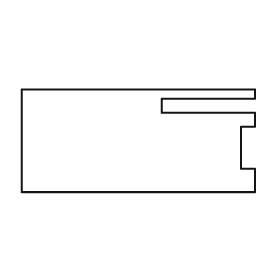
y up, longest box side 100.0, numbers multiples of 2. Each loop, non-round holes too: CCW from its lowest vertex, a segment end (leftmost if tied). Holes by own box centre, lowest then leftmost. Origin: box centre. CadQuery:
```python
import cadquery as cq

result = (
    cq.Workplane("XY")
    .moveTo(-50.0, -22.0)
    .lineTo(50.0, -22.0)
    .lineTo(50.0, -12.0)
    .lineTo(44.0, -12.0)
    .lineTo(44.0, 6.0)
    .lineTo(50.0, 6.0)
    .lineTo(50.0, 12.0)
    .lineTo(10.0, 12.0)
    .lineTo(10.0, 18.0)
    .lineTo(50.0, 18.0)
    .lineTo(50.0, 22.0)
    .lineTo(-50.0, 22.0)
    .close()
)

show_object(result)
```